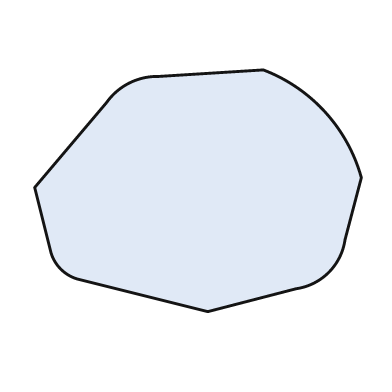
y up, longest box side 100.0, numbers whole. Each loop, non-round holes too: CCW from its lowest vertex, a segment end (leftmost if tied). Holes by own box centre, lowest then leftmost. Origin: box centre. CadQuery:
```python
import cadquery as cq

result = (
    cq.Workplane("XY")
    .moveTo(3.0, -37.0)
    .lineTo(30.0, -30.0)
    .threePointArc((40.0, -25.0), (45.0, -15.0))
    .lineTo(50.0, 4.0)
    .threePointArc((39.0, 24.0), (20.0, 37.0))
    .lineTo(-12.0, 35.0)
    .threePointArc((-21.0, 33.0), (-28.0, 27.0))
    .lineTo(-50.0, 1.0)
    .lineTo(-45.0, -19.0)
    .threePointArc((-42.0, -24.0), (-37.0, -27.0))
    .close()
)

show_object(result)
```